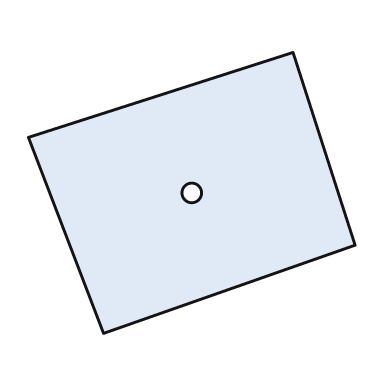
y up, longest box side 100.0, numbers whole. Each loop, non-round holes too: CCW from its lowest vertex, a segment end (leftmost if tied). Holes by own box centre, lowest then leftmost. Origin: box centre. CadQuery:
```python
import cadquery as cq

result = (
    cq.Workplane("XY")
    .moveTo(-27.0, -43.0)
    .lineTo(50.0, -16.0)
    .lineTo(31.0, 43.0)
    .lineTo(-50.0, 17.0)
    .close()
    .moveTo(0.0, 0.0)
    .circle(3.0)
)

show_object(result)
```